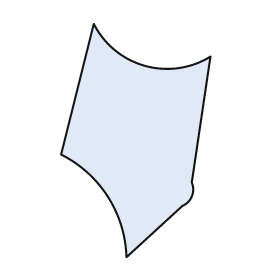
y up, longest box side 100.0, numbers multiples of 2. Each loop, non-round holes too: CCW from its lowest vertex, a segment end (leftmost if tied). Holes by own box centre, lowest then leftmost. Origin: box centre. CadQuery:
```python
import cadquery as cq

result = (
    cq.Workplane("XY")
    .moveTo(-4.0, -50.0)
    .lineTo(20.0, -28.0)
    .threePointArc((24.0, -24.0), (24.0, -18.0))
    .lineTo(32.0, 36.0)
    .threePointArc((4.0, 32.0), (-18.0, 50.0))
    .lineTo(-32.0, -6.0)
    .threePointArc((-12.0, -24.0), (-4.0, -50.0))
    .close()
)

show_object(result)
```